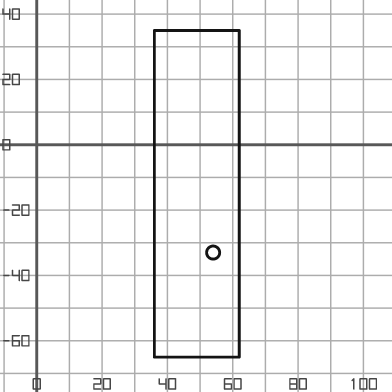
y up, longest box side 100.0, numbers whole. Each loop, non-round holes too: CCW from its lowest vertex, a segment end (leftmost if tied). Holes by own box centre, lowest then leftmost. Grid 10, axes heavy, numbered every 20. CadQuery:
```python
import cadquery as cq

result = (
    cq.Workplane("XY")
    .moveTo(36.0, -65.0)
    .lineTo(62.0, -65.0)
    .lineTo(62.0, 35.0)
    .lineTo(36.0, 35.0)
    .close()
    .moveTo(54.0, -33.0)
    .circle(2.0)
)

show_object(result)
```